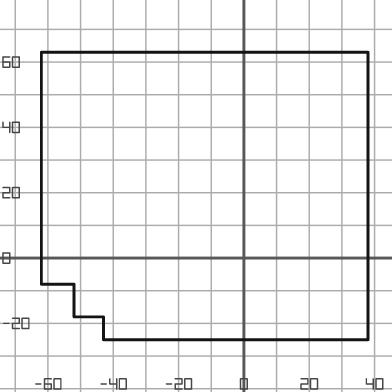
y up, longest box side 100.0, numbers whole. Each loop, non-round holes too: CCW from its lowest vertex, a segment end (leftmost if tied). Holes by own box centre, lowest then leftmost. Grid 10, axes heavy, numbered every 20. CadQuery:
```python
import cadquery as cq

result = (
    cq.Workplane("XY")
    .moveTo(-43.0, -25.0)
    .lineTo(38.0, -25.0)
    .lineTo(38.0, 63.0)
    .lineTo(-62.0, 63.0)
    .lineTo(-62.0, -8.0)
    .lineTo(-52.0, -8.0)
    .lineTo(-52.0, -18.0)
    .lineTo(-43.0, -18.0)
    .close()
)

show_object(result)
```